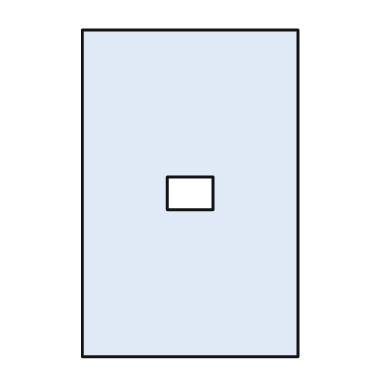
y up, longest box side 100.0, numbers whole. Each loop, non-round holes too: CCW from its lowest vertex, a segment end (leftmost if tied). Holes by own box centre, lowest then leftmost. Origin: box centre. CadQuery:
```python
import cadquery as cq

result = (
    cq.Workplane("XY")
    .moveTo(-33.0, -50.0)
    .lineTo(33.0, -50.0)
    .lineTo(33.0, 50.0)
    .lineTo(-33.0, 50.0)
    .close()
    .moveTo(-7.0, -5.0)
    .lineTo(7.0, -5.0)
    .lineTo(7.0, 5.0)
    .lineTo(-7.0, 5.0)
    .close()
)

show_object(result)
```